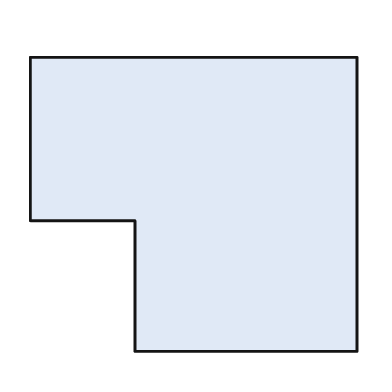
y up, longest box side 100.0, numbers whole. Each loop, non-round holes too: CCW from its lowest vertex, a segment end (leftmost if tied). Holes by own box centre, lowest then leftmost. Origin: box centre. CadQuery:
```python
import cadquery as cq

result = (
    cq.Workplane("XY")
    .moveTo(-18.0, -45.0)
    .lineTo(50.0, -45.0)
    .lineTo(50.0, 45.0)
    .lineTo(-50.0, 45.0)
    .lineTo(-50.0, -5.0)
    .lineTo(-18.0, -5.0)
    .close()
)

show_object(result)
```